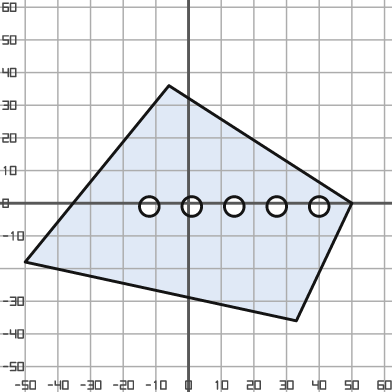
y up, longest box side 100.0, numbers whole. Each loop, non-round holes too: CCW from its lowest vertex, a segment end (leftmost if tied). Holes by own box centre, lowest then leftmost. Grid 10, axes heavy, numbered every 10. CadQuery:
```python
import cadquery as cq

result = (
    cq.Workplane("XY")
    .moveTo(33.0, -36.0)
    .lineTo(50.0, 0.0)
    .lineTo(-6.0, 36.0)
    .lineTo(-50.0, -18.0)
    .close()
    .moveTo(-12.0, -1.0)
    .circle(3.0)
    .moveTo(1.0, -1.0)
    .circle(3.0)
    .moveTo(14.0, -1.0)
    .circle(3.0)
    .moveTo(27.0, -1.0)
    .circle(3.0)
    .moveTo(40.0, -1.0)
    .circle(3.0)
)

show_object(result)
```